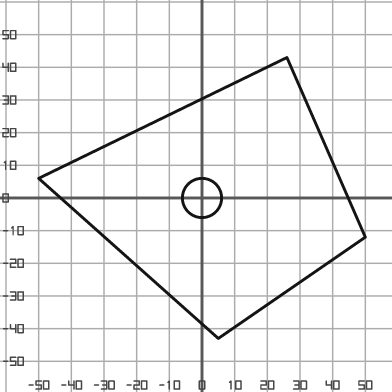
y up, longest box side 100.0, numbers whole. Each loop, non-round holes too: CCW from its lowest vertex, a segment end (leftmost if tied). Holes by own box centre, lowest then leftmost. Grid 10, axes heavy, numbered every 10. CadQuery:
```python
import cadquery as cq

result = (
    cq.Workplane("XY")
    .moveTo(5.0, -43.0)
    .lineTo(50.0, -12.0)
    .lineTo(26.0, 43.0)
    .lineTo(-50.0, 6.0)
    .close()
    .moveTo(0.0, 0.0)
    .circle(6.0)
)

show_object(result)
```